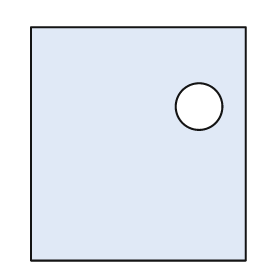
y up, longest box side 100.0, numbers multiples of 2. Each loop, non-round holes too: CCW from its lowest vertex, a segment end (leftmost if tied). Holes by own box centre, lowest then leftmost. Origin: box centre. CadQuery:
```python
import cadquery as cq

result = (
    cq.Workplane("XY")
    .moveTo(-46.0, -50.0)
    .lineTo(46.0, -50.0)
    .lineTo(46.0, 50.0)
    .lineTo(-46.0, 50.0)
    .close()
    .moveTo(26.0, 16.0)
    .circle(10.0)
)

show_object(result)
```